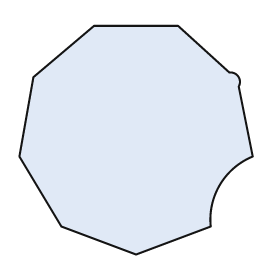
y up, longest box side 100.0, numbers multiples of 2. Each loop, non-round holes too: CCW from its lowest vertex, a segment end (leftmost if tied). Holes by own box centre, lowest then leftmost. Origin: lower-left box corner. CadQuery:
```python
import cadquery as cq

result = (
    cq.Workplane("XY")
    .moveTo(50.0, 0.0)
    .lineTo(82.0, 12.0)
    .threePointArc((86.0, 30.0), (100.0, 42.0))
    .lineTo(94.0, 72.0)
    .threePointArc((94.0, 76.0), (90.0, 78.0))
    .lineTo(68.0, 98.0)
    .lineTo(32.0, 98.0)
    .lineTo(6.0, 76.0)
    .lineTo(0.0, 42.0)
    .lineTo(18.0, 12.0)
    .close()
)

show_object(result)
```